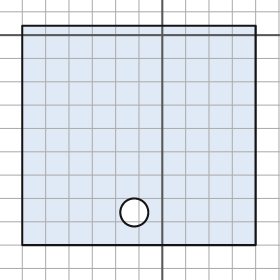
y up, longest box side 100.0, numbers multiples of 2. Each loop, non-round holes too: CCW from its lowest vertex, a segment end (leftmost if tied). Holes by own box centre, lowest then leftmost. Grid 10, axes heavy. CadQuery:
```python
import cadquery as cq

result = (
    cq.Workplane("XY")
    .moveTo(-60.0, -90.0)
    .lineTo(40.0, -90.0)
    .lineTo(40.0, 4.0)
    .lineTo(-60.0, 4.0)
    .close()
    .moveTo(-12.0, -76.0)
    .circle(6.0)
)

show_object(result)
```